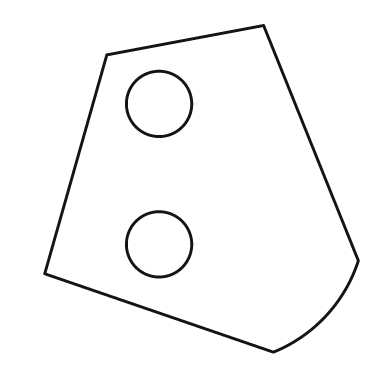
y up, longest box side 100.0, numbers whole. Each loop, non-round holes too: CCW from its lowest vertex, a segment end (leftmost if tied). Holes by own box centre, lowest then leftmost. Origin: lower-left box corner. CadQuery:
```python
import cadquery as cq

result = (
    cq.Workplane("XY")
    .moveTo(70.0, 0.0)
    .threePointArc((86.0, 11.0), (96.0, 28.0))
    .lineTo(67.0, 100.0)
    .lineTo(19.0, 91.0)
    .lineTo(0.0, 24.0)
    .close()
    .moveTo(35.0, 33.0)
    .circle(10.0)
    .moveTo(35.0, 76.0)
    .circle(10.0)
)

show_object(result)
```